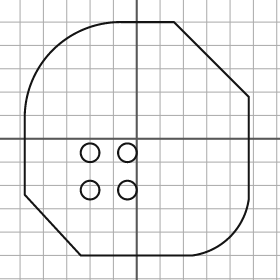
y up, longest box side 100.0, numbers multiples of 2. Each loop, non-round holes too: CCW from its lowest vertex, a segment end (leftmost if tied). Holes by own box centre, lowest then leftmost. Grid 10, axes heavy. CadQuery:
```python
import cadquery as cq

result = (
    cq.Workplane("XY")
    .moveTo(-24.0, -50.0)
    .lineTo(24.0, -50.0)
    .threePointArc((40.0, -42.0), (48.0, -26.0))
    .lineTo(48.0, 18.0)
    .lineTo(16.0, 50.0)
    .lineTo(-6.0, 50.0)
    .threePointArc((-36.0, 38.0), (-48.0, 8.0))
    .lineTo(-48.0, -24.0)
    .close()
    .moveTo(-20.0, -22.0)
    .circle(4.0)
    .moveTo(-4.0, -22.0)
    .circle(4.0)
    .moveTo(-20.0, -6.0)
    .circle(4.0)
    .moveTo(-4.0, -6.0)
    .circle(4.0)
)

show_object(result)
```